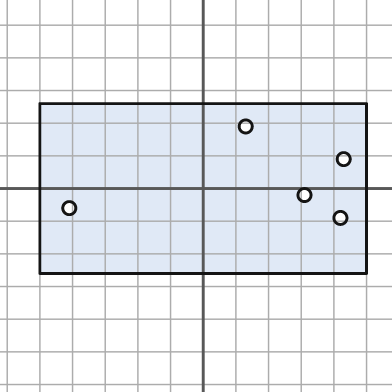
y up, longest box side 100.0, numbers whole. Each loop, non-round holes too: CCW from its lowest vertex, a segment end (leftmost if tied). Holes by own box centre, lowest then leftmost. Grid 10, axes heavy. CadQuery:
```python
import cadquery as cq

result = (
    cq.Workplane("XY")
    .moveTo(-50.0, -26.0)
    .lineTo(50.0, -26.0)
    .lineTo(50.0, 26.0)
    .lineTo(-50.0, 26.0)
    .close()
    .moveTo(42.0, -9.0)
    .circle(2.0)
    .moveTo(-41.0, -6.0)
    .circle(2.0)
    .moveTo(31.0, -2.0)
    .circle(2.0)
    .moveTo(43.0, 9.0)
    .circle(2.0)
    .moveTo(13.0, 19.0)
    .circle(2.0)
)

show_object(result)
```